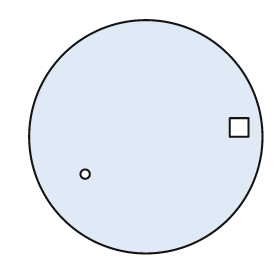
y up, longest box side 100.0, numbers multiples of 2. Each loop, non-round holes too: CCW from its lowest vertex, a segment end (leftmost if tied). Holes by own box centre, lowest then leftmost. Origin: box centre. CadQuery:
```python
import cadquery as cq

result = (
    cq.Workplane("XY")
    .moveTo(0.0, 0.0)
    .circle(50.0)
    .moveTo(-26.0, -16.0)
    .circle(2.0)
    .moveTo(36.0, 0.0)
    .lineTo(44.0, 0.0)
    .lineTo(44.0, 8.0)
    .lineTo(36.0, 8.0)
    .close()
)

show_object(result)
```